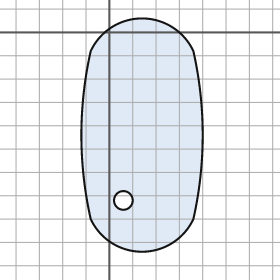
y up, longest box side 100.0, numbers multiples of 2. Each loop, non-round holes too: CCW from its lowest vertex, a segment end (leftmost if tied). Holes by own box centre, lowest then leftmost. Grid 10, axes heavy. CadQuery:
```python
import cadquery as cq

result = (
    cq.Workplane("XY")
    .moveTo(-8.0, -80.0)
    .threePointArc((14.0, -94.0), (36.0, -80.0))
    .threePointArc((40.0, -44.0), (36.0, -8.0))
    .threePointArc((14.0, 6.0), (-8.0, -8.0))
    .threePointArc((-12.0, -44.0), (-8.0, -80.0))
    .close()
    .moveTo(6.0, -72.0)
    .circle(4.0)
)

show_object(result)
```